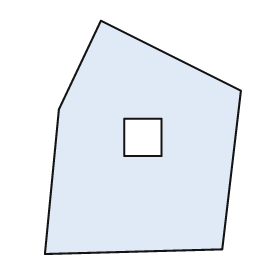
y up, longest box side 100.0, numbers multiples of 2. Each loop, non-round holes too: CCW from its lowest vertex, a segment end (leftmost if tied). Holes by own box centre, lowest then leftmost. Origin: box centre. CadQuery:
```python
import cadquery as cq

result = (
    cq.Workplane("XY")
    .moveTo(-42.0, -50.0)
    .lineTo(34.0, -48.0)
    .lineTo(42.0, 20.0)
    .lineTo(-18.0, 50.0)
    .lineTo(-36.0, 12.0)
    .close()
    .moveTo(-8.0, -8.0)
    .lineTo(8.0, -8.0)
    .lineTo(8.0, 8.0)
    .lineTo(-8.0, 8.0)
    .close()
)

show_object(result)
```